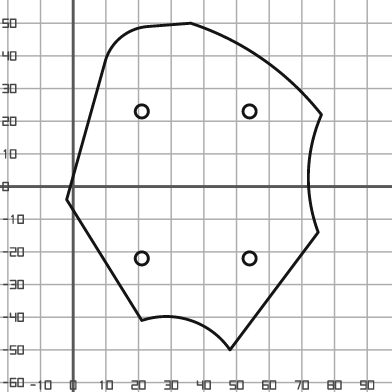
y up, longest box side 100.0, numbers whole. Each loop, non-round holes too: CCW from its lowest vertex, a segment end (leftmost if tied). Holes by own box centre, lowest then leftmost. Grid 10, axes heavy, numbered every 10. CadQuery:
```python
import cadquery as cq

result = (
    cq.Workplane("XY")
    .moveTo(48.0, -50.0)
    .lineTo(75.0, -14.0)
    .threePointArc((72.0, 4.0), (76.0, 22.0))
    .threePointArc((58.0, 39.0), (36.0, 50.0))
    .lineTo(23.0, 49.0)
    .threePointArc((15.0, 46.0), (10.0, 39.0))
    .lineTo(-2.0, -4.0)
    .lineTo(21.0, -41.0)
    .threePointArc((36.0, -41.0), (48.0, -50.0))
    .close()
    .moveTo(21.0, -22.0)
    .circle(2.0)
    .moveTo(54.0, -22.0)
    .circle(2.0)
    .moveTo(21.0, 23.0)
    .circle(2.0)
    .moveTo(54.0, 23.0)
    .circle(2.0)
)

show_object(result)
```